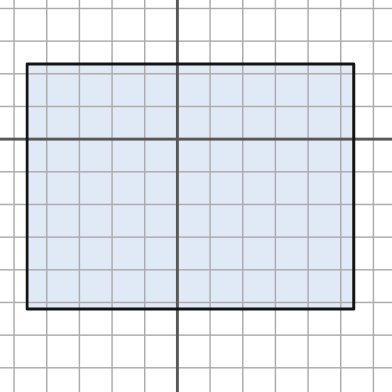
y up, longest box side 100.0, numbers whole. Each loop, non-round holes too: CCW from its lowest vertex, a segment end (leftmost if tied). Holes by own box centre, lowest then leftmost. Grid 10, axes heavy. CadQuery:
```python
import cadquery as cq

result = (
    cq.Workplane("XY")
    .moveTo(-46.0, -52.0)
    .lineTo(54.0, -52.0)
    .lineTo(54.0, 23.0)
    .lineTo(-46.0, 23.0)
    .close()
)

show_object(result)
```